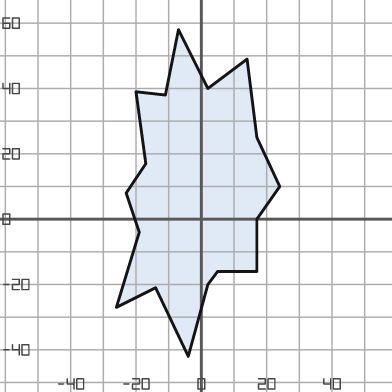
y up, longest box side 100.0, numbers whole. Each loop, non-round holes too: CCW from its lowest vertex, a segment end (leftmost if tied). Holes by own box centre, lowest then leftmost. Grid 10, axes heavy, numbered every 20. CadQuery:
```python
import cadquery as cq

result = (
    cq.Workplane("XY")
    .moveTo(-4.0, -42.0)
    .lineTo(2.0, -20.0)
    .lineTo(5.0, -16.0)
    .lineTo(17.0, -16.0)
    .lineTo(17.0, 0.0)
    .lineTo(24.0, 10.0)
    .lineTo(17.0, 25.0)
    .lineTo(14.0, 49.0)
    .lineTo(2.0, 40.0)
    .lineTo(-7.0, 58.0)
    .lineTo(-11.0, 38.0)
    .lineTo(-20.0, 39.0)
    .lineTo(-17.0, 17.0)
    .lineTo(-23.0, 8.0)
    .lineTo(-19.0, -4.0)
    .lineTo(-26.0, -27.0)
    .lineTo(-14.0, -21.0)
    .close()
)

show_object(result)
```